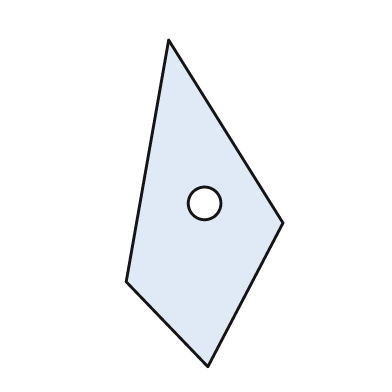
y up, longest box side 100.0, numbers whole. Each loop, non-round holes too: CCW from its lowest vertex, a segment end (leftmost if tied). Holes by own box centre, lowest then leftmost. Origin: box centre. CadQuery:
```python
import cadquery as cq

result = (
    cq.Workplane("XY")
    .moveTo(1.0, -50.0)
    .lineTo(24.0, -6.0)
    .lineTo(-11.0, 50.0)
    .lineTo(-24.0, -24.0)
    .close()
    .moveTo(0.0, 0.0)
    .circle(5.0)
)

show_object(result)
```